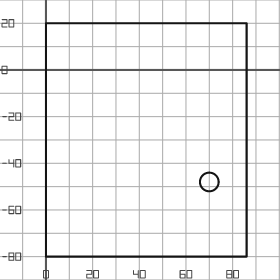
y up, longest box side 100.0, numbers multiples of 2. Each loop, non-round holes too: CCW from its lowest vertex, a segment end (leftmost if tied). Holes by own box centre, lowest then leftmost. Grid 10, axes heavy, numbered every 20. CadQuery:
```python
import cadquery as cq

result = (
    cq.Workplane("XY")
    .moveTo(0.0, -80.0)
    .lineTo(86.0, -80.0)
    .lineTo(86.0, 20.0)
    .lineTo(0.0, 20.0)
    .close()
    .moveTo(70.0, -48.0)
    .circle(4.0)
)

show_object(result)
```